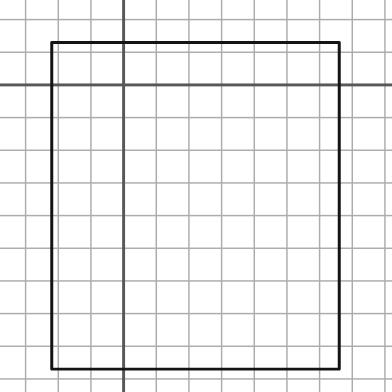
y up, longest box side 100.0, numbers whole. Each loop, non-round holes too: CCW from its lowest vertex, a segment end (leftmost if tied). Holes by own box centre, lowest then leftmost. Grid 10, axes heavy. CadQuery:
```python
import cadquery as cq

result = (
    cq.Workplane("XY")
    .moveTo(-22.0, -87.0)
    .lineTo(66.0, -87.0)
    .lineTo(66.0, 13.0)
    .lineTo(-22.0, 13.0)
    .close()
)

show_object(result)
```